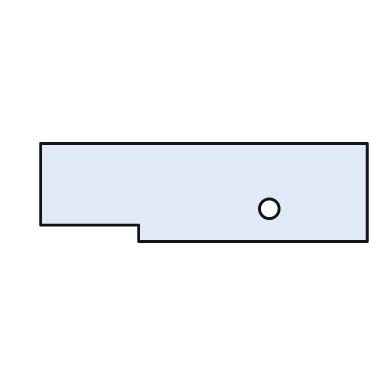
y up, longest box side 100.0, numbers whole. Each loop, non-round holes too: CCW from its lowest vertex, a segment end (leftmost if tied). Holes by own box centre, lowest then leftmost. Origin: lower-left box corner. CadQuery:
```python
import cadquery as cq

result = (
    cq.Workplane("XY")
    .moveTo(30.0, 0.0)
    .lineTo(100.0, 0.0)
    .lineTo(100.0, 30.0)
    .lineTo(0.0, 30.0)
    .lineTo(0.0, 5.0)
    .lineTo(30.0, 5.0)
    .close()
    .moveTo(70.0, 10.0)
    .circle(3.0)
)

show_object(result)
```